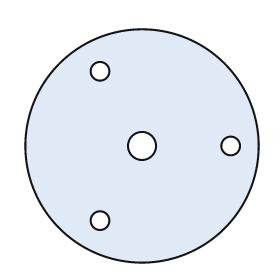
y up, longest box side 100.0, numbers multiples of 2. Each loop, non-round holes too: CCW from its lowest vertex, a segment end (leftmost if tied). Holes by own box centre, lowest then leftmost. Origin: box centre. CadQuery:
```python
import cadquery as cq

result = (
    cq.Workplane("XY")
    .moveTo(0.0, 0.0)
    .circle(50.0)
    .moveTo(-18.0, -32.0)
    .circle(4.0)
    .moveTo(0.0, 0.0)
    .circle(6.0)
    .moveTo(38.0, 0.0)
    .circle(4.0)
    .moveTo(-18.0, 32.0)
    .circle(4.0)
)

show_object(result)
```